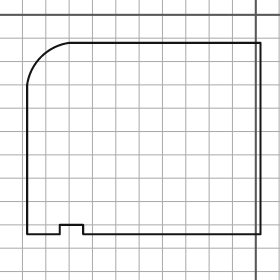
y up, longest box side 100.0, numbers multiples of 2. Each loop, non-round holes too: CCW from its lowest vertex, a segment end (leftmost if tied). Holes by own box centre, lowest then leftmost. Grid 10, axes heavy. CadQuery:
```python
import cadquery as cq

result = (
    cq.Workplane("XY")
    .moveTo(-98.0, -94.0)
    .lineTo(-84.0, -94.0)
    .lineTo(-84.0, -90.0)
    .lineTo(-74.0, -90.0)
    .lineTo(-74.0, -94.0)
    .lineTo(2.0, -94.0)
    .lineTo(2.0, -12.0)
    .lineTo(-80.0, -12.0)
    .threePointArc((-92.0, -18.0), (-98.0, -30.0))
    .close()
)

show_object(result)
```